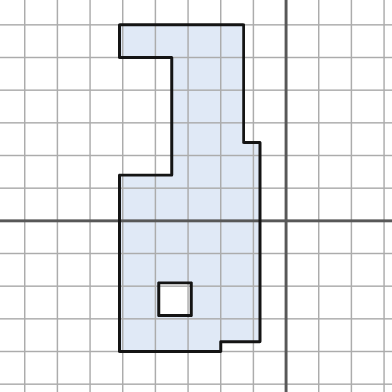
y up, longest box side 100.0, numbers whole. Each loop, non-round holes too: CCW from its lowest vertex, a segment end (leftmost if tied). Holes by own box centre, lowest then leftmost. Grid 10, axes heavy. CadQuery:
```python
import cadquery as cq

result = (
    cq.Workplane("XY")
    .moveTo(-51.0, -40.0)
    .lineTo(-20.0, -40.0)
    .lineTo(-20.0, -37.0)
    .lineTo(-8.0, -37.0)
    .lineTo(-8.0, 24.0)
    .lineTo(-13.0, 24.0)
    .lineTo(-13.0, 60.0)
    .lineTo(-51.0, 60.0)
    .lineTo(-51.0, 50.0)
    .lineTo(-35.0, 50.0)
    .lineTo(-35.0, 14.0)
    .lineTo(-51.0, 14.0)
    .close()
    .moveTo(-39.0, -29.0)
    .lineTo(-29.0, -29.0)
    .lineTo(-29.0, -19.0)
    .lineTo(-39.0, -19.0)
    .close()
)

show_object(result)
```